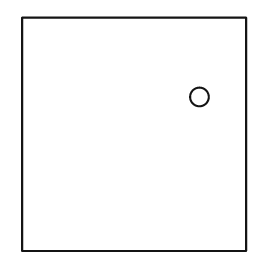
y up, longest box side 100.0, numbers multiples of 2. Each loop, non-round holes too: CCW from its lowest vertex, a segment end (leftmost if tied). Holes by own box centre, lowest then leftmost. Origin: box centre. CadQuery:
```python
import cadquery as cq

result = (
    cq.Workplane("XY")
    .moveTo(-48.0, -50.0)
    .lineTo(48.0, -50.0)
    .lineTo(48.0, 50.0)
    .lineTo(-48.0, 50.0)
    .close()
    .moveTo(28.0, 16.0)
    .circle(4.0)
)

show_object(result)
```